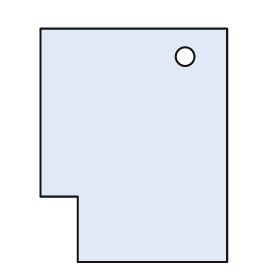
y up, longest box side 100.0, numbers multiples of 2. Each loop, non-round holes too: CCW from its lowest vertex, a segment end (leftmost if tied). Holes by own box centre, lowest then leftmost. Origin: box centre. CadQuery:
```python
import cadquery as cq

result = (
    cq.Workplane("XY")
    .moveTo(-24.0, -50.0)
    .lineTo(40.0, -50.0)
    .lineTo(40.0, 50.0)
    .lineTo(-40.0, 50.0)
    .lineTo(-40.0, -22.0)
    .lineTo(-24.0, -22.0)
    .close()
    .moveTo(22.0, 38.0)
    .circle(4.0)
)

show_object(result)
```